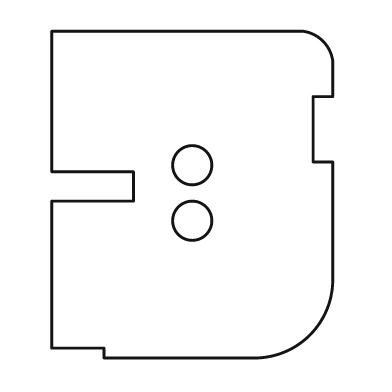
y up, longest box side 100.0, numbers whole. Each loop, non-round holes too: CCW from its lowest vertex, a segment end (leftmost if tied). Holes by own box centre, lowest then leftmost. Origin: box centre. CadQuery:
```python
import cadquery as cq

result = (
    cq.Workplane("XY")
    .moveTo(-27.0, -50.0)
    .lineTo(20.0, -50.0)
    .threePointArc((36.0, -43.0), (43.0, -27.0))
    .lineTo(43.0, 10.0)
    .lineTo(37.0, 10.0)
    .lineTo(37.0, 30.0)
    .lineTo(43.0, 30.0)
    .lineTo(43.0, 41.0)
    .threePointArc((40.0, 47.0), (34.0, 50.0))
    .lineTo(-43.0, 50.0)
    .lineTo(-43.0, 7.0)
    .lineTo(-18.0, 7.0)
    .lineTo(-18.0, -2.0)
    .lineTo(-43.0, -2.0)
    .lineTo(-43.0, -47.0)
    .lineTo(-27.0, -47.0)
    .close()
    .moveTo(0.0, -8.0)
    .circle(6.0)
    .moveTo(0.0, 9.0)
    .circle(6.0)
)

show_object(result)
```